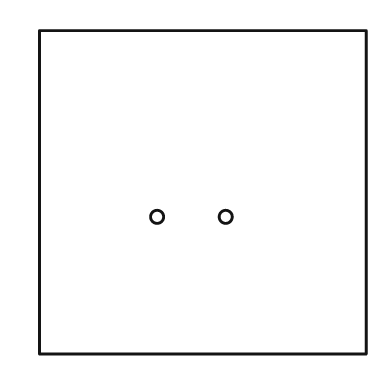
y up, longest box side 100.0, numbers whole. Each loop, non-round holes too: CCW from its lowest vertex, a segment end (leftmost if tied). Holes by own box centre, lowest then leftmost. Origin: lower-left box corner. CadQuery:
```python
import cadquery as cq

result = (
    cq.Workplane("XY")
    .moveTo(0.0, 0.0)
    .lineTo(100.0, 0.0)
    .lineTo(100.0, 99.0)
    .lineTo(0.0, 99.0)
    .close()
    .moveTo(36.0, 42.0)
    .circle(2.0)
    .moveTo(57.0, 42.0)
    .circle(2.0)
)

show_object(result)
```